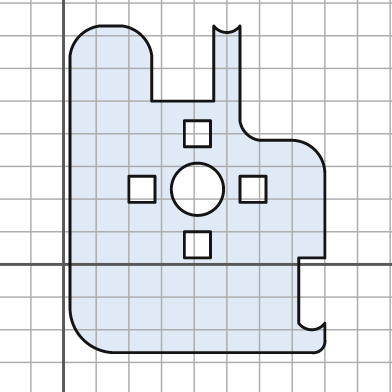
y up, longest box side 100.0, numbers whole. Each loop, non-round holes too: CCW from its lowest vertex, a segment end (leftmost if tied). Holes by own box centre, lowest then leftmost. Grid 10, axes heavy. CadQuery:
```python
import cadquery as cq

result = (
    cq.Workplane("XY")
    .moveTo(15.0, -27.0)
    .lineTo(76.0, -27.0)
    .threePointArc((79.0, -26.0), (80.0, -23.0))
    .lineTo(80.0, -18.0)
    .threePointArc((76.0, -20.0), (72.0, -18.0))
    .lineTo(72.0, 2.0)
    .lineTo(80.0, 2.0)
    .lineTo(80.0, 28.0)
    .threePointArc((77.0, 35.0), (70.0, 38.0))
    .lineTo(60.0, 38.0)
    .threePointArc((56.0, 40.0), (54.0, 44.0))
    .lineTo(54.0, 73.0)
    .threePointArc((50.0, 71.0), (46.0, 73.0))
    .lineTo(46.0, 50.0)
    .lineTo(27.0, 50.0)
    .lineTo(27.0, 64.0)
    .threePointArc((24.0, 70.0), (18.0, 73.0))
    .lineTo(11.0, 73.0)
    .threePointArc((5.0, 70.0), (2.0, 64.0))
    .lineTo(2.0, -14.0)
    .threePointArc((6.0, -23.0), (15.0, -27.0))
    .close()
    .moveTo(37.0, 2.0)
    .lineTo(45.0, 2.0)
    .lineTo(45.0, 10.0)
    .lineTo(37.0, 10.0)
    .close()
    .moveTo(20.0, 19.0)
    .lineTo(28.0, 19.0)
    .lineTo(28.0, 27.0)
    .lineTo(20.0, 27.0)
    .close()
    .moveTo(41.0, 23.0)
    .circle(8.0)
    .moveTo(54.0, 19.0)
    .lineTo(62.0, 19.0)
    .lineTo(62.0, 27.0)
    .lineTo(54.0, 27.0)
    .close()
    .moveTo(37.0, 36.0)
    .lineTo(45.0, 36.0)
    .lineTo(45.0, 44.0)
    .lineTo(37.0, 44.0)
    .close()
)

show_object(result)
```